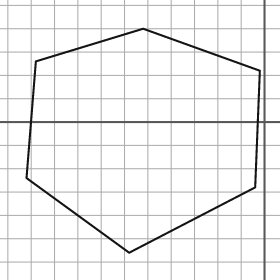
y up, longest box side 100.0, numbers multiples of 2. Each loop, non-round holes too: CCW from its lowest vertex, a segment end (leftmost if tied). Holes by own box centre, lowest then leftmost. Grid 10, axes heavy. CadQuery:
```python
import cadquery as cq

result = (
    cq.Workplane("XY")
    .moveTo(-58.0, -56.0)
    .lineTo(-4.0, -28.0)
    .lineTo(-2.0, 22.0)
    .lineTo(-52.0, 40.0)
    .lineTo(-98.0, 26.0)
    .lineTo(-102.0, -24.0)
    .close()
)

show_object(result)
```